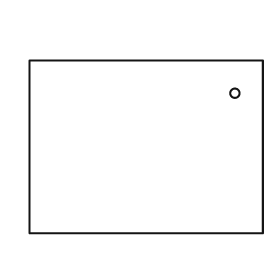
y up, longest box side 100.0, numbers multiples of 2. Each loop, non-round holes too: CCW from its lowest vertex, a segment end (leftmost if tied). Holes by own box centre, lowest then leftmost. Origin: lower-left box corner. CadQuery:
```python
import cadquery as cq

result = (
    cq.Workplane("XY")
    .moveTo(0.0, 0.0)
    .lineTo(100.0, 0.0)
    .lineTo(100.0, 74.0)
    .lineTo(0.0, 74.0)
    .close()
    .moveTo(88.0, 60.0)
    .circle(2.0)
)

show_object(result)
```